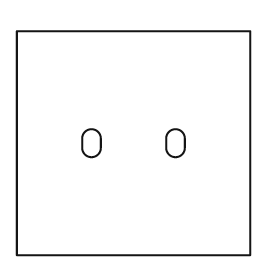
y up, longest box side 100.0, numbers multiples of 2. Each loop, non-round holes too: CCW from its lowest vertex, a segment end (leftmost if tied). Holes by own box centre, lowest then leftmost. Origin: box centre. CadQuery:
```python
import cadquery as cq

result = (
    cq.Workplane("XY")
    .moveTo(-50.0, -48.0)
    .lineTo(50.0, -48.0)
    .lineTo(50.0, 48.0)
    .lineTo(-50.0, 48.0)
    .close()
    .moveTo(-22.0, -2.0)
    .threePointArc((-18.0, -6.0), (-14.0, -2.0))
    .lineTo(-14.0, 2.0)
    .threePointArc((-18.0, 6.0), (-22.0, 2.0))
    .close()
    .moveTo(14.0, -2.0)
    .threePointArc((18.0, -6.0), (22.0, -2.0))
    .lineTo(22.0, 2.0)
    .threePointArc((18.0, 6.0), (14.0, 2.0))
    .close()
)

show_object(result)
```